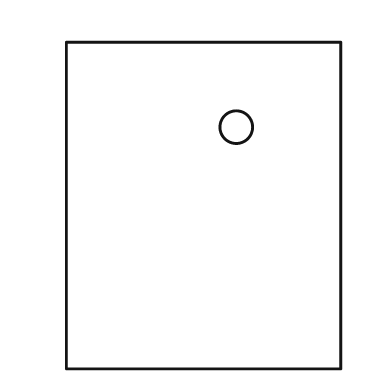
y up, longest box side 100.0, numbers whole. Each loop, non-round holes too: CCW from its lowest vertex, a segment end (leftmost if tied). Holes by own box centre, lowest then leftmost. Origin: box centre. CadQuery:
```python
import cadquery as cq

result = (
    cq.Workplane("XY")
    .moveTo(-42.0, -50.0)
    .lineTo(42.0, -50.0)
    .lineTo(42.0, 50.0)
    .lineTo(-42.0, 50.0)
    .close()
    .moveTo(10.0, 24.0)
    .circle(5.0)
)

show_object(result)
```